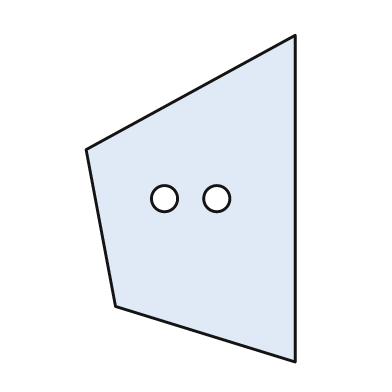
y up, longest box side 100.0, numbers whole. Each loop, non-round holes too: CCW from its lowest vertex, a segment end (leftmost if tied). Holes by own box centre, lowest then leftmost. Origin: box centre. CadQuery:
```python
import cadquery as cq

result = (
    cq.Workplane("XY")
    .moveTo(32.0, -50.0)
    .lineTo(32.0, 50.0)
    .lineTo(-32.0, 15.0)
    .lineTo(-23.0, -33.0)
    .close()
    .moveTo(-8.0, 0.0)
    .circle(4.0)
    .moveTo(8.0, 0.0)
    .circle(4.0)
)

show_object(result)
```